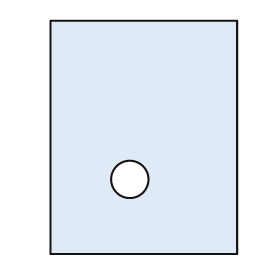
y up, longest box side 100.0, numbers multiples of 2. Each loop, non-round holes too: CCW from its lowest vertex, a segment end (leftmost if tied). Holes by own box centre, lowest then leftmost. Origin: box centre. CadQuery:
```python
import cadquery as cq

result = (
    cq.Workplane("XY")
    .moveTo(-40.0, -50.0)
    .lineTo(40.0, -50.0)
    .lineTo(40.0, 50.0)
    .lineTo(-40.0, 50.0)
    .close()
    .moveTo(-6.0, -18.0)
    .circle(8.0)
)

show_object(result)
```